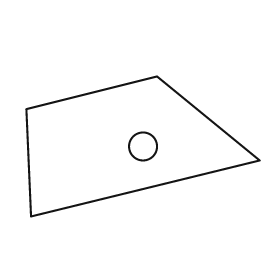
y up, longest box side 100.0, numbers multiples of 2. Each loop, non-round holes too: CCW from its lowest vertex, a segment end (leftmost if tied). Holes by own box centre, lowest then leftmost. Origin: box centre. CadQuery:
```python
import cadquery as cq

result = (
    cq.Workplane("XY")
    .moveTo(-48.0, -30.0)
    .lineTo(50.0, -6.0)
    .lineTo(6.0, 30.0)
    .lineTo(-50.0, 16.0)
    .close()
    .moveTo(0.0, 0.0)
    .circle(6.0)
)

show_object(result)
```